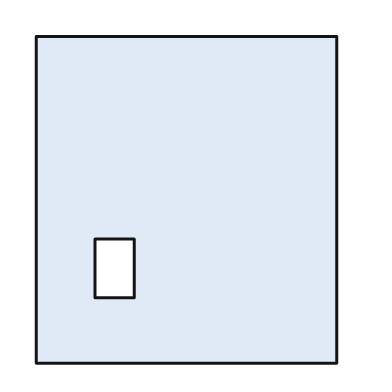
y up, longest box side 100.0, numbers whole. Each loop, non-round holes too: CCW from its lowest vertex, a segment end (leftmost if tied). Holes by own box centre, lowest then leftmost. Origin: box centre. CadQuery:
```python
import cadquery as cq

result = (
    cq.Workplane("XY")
    .moveTo(-46.0, -50.0)
    .lineTo(46.0, -50.0)
    .lineTo(46.0, 50.0)
    .lineTo(-46.0, 50.0)
    .close()
    .moveTo(-28.0, -30.0)
    .lineTo(-16.0, -30.0)
    .lineTo(-16.0, -12.0)
    .lineTo(-28.0, -12.0)
    .close()
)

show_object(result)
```